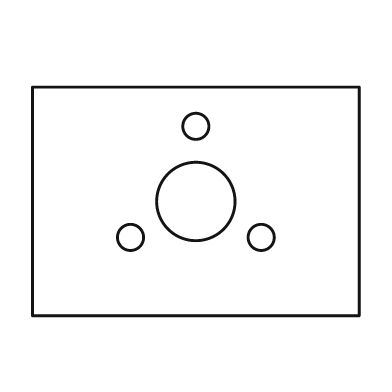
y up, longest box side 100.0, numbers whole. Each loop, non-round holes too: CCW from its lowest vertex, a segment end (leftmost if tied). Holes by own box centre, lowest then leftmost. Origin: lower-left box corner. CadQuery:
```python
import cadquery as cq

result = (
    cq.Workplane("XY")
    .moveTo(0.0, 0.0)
    .lineTo(100.0, 0.0)
    .lineTo(100.0, 70.0)
    .lineTo(0.0, 70.0)
    .close()
    .moveTo(30.0, 24.0)
    .circle(4.0)
    .moveTo(70.0, 24.0)
    .circle(4.0)
    .moveTo(50.0, 35.0)
    .circle(12.0)
    .moveTo(50.0, 58.0)
    .circle(4.0)
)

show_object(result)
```